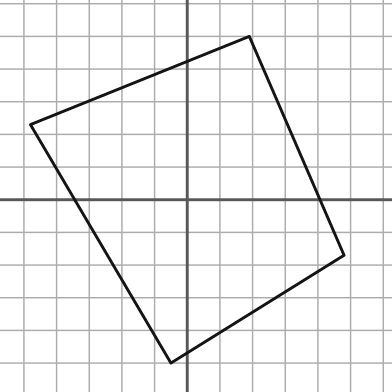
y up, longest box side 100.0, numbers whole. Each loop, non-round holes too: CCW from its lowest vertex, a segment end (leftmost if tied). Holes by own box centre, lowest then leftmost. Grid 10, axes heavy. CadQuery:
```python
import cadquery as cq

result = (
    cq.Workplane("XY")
    .moveTo(-5.0, -50.0)
    .lineTo(48.0, -17.0)
    .lineTo(19.0, 50.0)
    .lineTo(-48.0, 23.0)
    .close()
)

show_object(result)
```